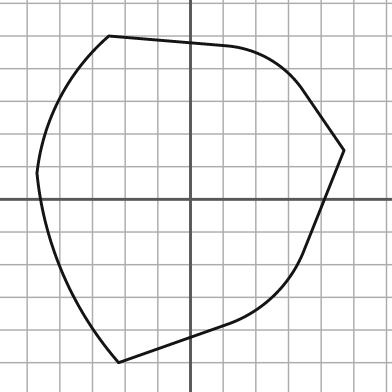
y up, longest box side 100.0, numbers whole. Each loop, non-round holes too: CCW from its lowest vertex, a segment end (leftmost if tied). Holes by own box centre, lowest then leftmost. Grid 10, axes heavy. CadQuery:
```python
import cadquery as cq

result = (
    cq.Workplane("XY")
    .moveTo(-22.0, -50.0)
    .lineTo(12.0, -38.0)
    .threePointArc((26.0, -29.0), (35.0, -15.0))
    .lineTo(47.0, 15.0)
    .lineTo(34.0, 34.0)
    .threePointArc((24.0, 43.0), (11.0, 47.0))
    .lineTo(-25.0, 50.0)
    .threePointArc((-40.0, 31.0), (-47.0, 8.0))
    .threePointArc((-39.0, -23.0), (-22.0, -50.0))
    .close()
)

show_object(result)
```